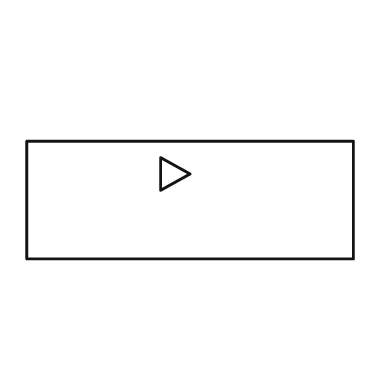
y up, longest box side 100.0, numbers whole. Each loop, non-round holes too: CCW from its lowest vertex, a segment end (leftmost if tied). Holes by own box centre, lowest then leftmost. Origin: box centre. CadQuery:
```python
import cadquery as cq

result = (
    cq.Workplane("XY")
    .moveTo(-50.0, -18.0)
    .lineTo(50.0, -18.0)
    .lineTo(50.0, 18.0)
    .lineTo(-50.0, 18.0)
    .close()
    .moveTo(-9.0, 3.0)
    .lineTo(0.0, 8.0)
    .lineTo(-9.0, 13.0)
    .close()
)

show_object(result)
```